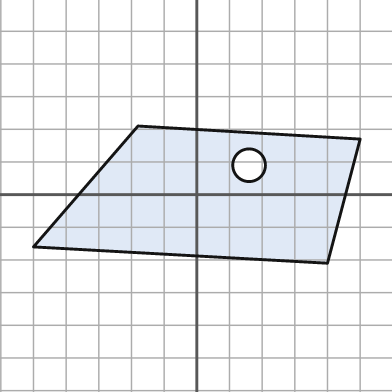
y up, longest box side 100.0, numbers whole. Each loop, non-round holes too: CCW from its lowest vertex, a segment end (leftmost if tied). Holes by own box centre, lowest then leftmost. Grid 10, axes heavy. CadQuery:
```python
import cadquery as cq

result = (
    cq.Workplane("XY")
    .moveTo(40.0, -21.0)
    .lineTo(50.0, 17.0)
    .lineTo(-18.0, 21.0)
    .lineTo(-50.0, -16.0)
    .close()
    .moveTo(16.0, 9.0)
    .circle(5.0)
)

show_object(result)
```